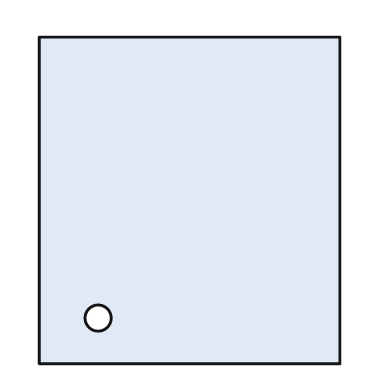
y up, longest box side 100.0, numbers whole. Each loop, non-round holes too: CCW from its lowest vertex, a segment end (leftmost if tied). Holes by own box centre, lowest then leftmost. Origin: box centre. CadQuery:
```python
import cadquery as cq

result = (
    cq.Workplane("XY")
    .moveTo(-46.0, -50.0)
    .lineTo(46.0, -50.0)
    .lineTo(46.0, 50.0)
    .lineTo(-46.0, 50.0)
    .close()
    .moveTo(-28.0, -36.0)
    .circle(4.0)
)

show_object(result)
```